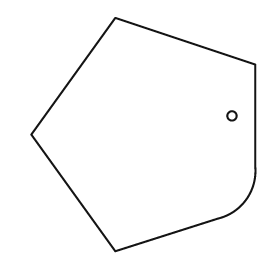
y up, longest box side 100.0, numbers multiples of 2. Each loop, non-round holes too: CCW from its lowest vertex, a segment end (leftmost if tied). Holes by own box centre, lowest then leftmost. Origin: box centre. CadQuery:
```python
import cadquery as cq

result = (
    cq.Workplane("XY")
    .moveTo(-12.0, -50.0)
    .lineTo(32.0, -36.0)
    .threePointArc((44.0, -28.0), (48.0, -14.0))
    .lineTo(48.0, 30.0)
    .lineTo(-12.0, 50.0)
    .lineTo(-48.0, 0.0)
    .close()
    .moveTo(38.0, 8.0)
    .circle(2.0)
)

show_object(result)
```